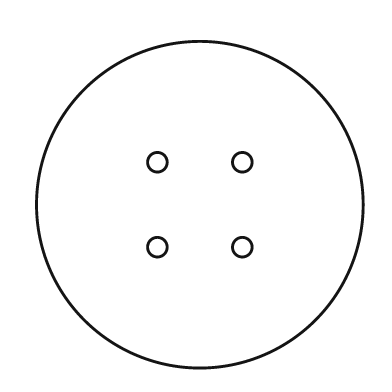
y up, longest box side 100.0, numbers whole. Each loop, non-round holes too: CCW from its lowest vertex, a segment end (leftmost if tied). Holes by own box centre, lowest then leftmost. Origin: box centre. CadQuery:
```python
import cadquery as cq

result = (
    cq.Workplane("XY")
    .moveTo(0.0, 0.0)
    .circle(50.0)
    .moveTo(-13.0, -13.0)
    .circle(3.0)
    .moveTo(13.0, -13.0)
    .circle(3.0)
    .moveTo(-13.0, 13.0)
    .circle(3.0)
    .moveTo(13.0, 13.0)
    .circle(3.0)
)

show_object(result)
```